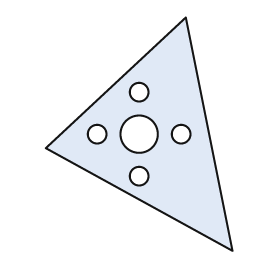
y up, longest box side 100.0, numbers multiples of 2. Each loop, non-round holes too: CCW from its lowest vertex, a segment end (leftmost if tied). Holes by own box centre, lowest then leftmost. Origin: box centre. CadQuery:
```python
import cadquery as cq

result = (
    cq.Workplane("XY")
    .moveTo(40.0, -50.0)
    .lineTo(20.0, 50.0)
    .lineTo(-40.0, -6.0)
    .close()
    .moveTo(0.0, -18.0)
    .circle(4.0)
    .moveTo(-18.0, 0.0)
    .circle(4.0)
    .moveTo(0.0, 0.0)
    .circle(8.0)
    .moveTo(18.0, 0.0)
    .circle(4.0)
    .moveTo(0.0, 18.0)
    .circle(4.0)
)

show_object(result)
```